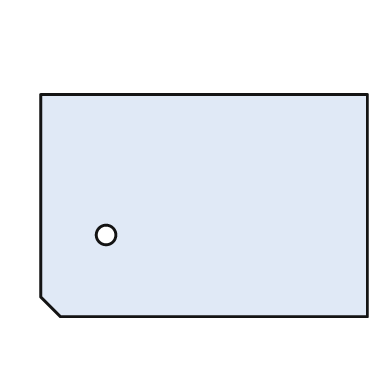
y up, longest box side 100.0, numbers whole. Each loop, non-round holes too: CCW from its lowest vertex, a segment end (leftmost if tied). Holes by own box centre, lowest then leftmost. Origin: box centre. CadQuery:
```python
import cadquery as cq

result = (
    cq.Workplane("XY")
    .moveTo(-44.0, -34.0)
    .lineTo(50.0, -34.0)
    .lineTo(50.0, 34.0)
    .lineTo(-50.0, 34.0)
    .lineTo(-50.0, -28.0)
    .close()
    .moveTo(-30.0, -9.0)
    .circle(3.0)
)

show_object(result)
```